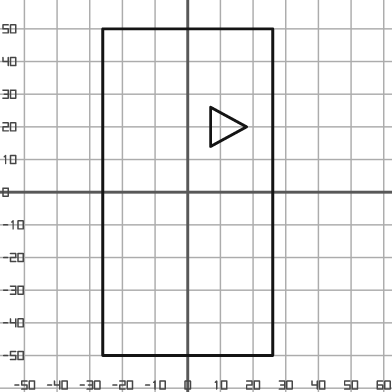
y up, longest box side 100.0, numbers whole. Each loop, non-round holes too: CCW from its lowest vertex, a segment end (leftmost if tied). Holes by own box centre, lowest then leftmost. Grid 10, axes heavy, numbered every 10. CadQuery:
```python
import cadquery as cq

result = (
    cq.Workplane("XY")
    .moveTo(-26.0, -50.0)
    .lineTo(26.0, -50.0)
    .lineTo(26.0, 50.0)
    .lineTo(-26.0, 50.0)
    .close()
    .moveTo(7.0, 14.0)
    .lineTo(18.0, 20.0)
    .lineTo(7.0, 26.0)
    .close()
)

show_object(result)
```